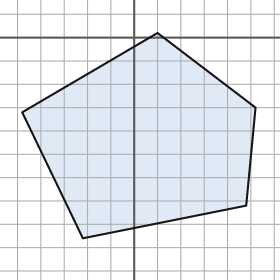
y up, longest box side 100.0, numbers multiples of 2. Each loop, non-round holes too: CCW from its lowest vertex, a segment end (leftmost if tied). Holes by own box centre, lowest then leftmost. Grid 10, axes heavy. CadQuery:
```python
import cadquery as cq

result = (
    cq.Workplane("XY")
    .moveTo(-22.0, -86.0)
    .lineTo(48.0, -72.0)
    .lineTo(52.0, -30.0)
    .lineTo(10.0, 2.0)
    .lineTo(-48.0, -32.0)
    .close()
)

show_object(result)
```